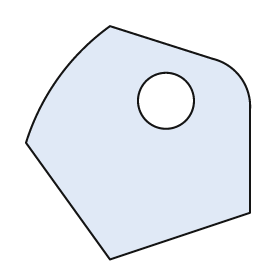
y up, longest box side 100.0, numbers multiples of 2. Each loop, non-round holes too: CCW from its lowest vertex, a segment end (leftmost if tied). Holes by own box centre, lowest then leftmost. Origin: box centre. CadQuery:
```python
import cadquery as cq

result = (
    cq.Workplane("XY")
    .moveTo(-12.0, -50.0)
    .lineTo(48.0, -30.0)
    .lineTo(48.0, 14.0)
    .threePointArc((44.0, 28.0), (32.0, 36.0))
    .lineTo(-12.0, 50.0)
    .threePointArc((-34.0, 28.0), (-48.0, 0.0))
    .close()
    .moveTo(12.0, 18.0)
    .circle(12.0)
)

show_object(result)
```